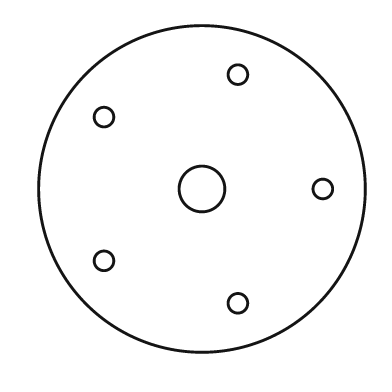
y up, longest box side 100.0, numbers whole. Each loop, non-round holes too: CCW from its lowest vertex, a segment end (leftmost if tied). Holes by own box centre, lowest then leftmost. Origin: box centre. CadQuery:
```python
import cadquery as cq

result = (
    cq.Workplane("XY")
    .moveTo(0.0, 0.0)
    .circle(50.0)
    .moveTo(11.0, -35.0)
    .circle(3.0)
    .moveTo(-30.0, -22.0)
    .circle(3.0)
    .moveTo(0.0, 0.0)
    .circle(7.0)
    .moveTo(37.0, 0.0)
    .circle(3.0)
    .moveTo(-30.0, 22.0)
    .circle(3.0)
    .moveTo(11.0, 35.0)
    .circle(3.0)
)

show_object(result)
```